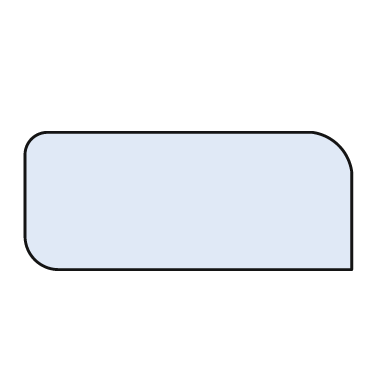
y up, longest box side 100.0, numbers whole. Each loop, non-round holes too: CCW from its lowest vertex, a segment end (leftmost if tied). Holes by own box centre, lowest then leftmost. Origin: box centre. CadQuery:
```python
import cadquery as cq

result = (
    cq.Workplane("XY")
    .moveTo(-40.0, -21.0)
    .lineTo(50.0, -21.0)
    .lineTo(50.0, 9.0)
    .threePointArc((46.0, 17.0), (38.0, 21.0))
    .lineTo(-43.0, 21.0)
    .threePointArc((-48.0, 19.0), (-50.0, 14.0))
    .lineTo(-50.0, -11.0)
    .threePointArc((-47.0, -18.0), (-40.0, -21.0))
    .close()
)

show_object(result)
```